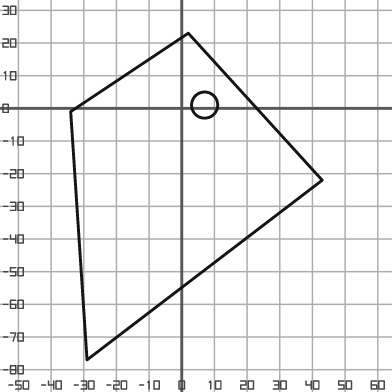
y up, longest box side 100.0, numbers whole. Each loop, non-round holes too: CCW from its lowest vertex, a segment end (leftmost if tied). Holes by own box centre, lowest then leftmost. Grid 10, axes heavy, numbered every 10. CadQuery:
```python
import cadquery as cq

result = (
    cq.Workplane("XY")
    .moveTo(-29.0, -77.0)
    .lineTo(43.0, -22.0)
    .lineTo(2.0, 23.0)
    .lineTo(-34.0, -1.0)
    .close()
    .moveTo(7.0, 1.0)
    .circle(4.0)
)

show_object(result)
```